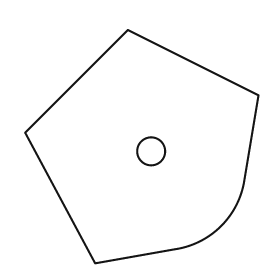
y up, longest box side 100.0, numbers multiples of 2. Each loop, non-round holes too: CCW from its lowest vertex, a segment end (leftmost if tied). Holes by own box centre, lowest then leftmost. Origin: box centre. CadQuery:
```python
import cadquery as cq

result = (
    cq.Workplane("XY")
    .moveTo(-20.0, -50.0)
    .lineTo(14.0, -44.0)
    .threePointArc((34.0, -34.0), (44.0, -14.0))
    .lineTo(50.0, 22.0)
    .lineTo(-6.0, 50.0)
    .lineTo(-50.0, 6.0)
    .close()
    .moveTo(4.0, -2.0)
    .circle(6.0)
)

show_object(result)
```